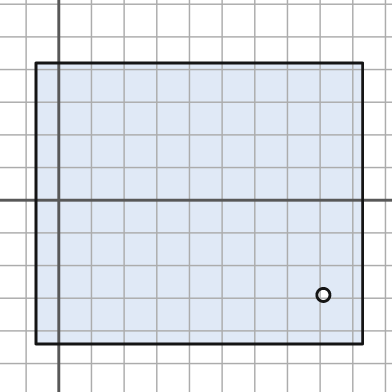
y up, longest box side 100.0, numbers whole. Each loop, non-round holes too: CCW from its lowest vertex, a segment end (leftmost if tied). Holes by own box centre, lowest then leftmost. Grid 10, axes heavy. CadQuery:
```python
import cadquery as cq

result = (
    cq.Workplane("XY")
    .moveTo(-7.0, -44.0)
    .lineTo(93.0, -44.0)
    .lineTo(93.0, 42.0)
    .lineTo(-7.0, 42.0)
    .close()
    .moveTo(81.0, -29.0)
    .circle(2.0)
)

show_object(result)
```